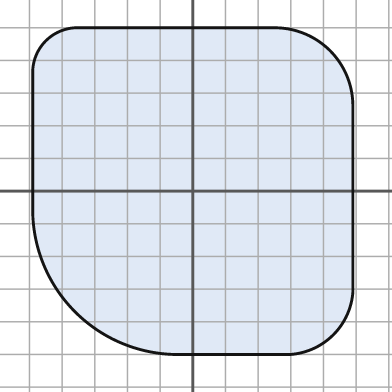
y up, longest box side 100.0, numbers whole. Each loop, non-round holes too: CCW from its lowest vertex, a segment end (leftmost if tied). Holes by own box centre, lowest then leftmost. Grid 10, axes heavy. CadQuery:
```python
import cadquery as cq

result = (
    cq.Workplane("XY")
    .moveTo(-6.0, -50.0)
    .lineTo(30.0, -50.0)
    .threePointArc((43.0, -44.0), (49.0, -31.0))
    .lineTo(49.0, 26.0)
    .threePointArc((42.0, 43.0), (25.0, 50.0))
    .lineTo(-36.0, 50.0)
    .threePointArc((-45.0, 46.0), (-49.0, 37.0))
    .lineTo(-49.0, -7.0)
    .threePointArc((-36.0, -37.0), (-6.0, -50.0))
    .close()
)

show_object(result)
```